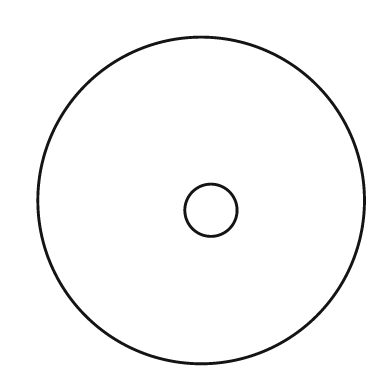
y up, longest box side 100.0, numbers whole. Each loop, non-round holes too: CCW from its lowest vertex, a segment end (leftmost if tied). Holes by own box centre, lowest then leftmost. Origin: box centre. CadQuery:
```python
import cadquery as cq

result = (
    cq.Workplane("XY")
    .moveTo(0.0, 0.0)
    .circle(50.0)
    .moveTo(3.0, -3.0)
    .circle(8.0)
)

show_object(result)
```